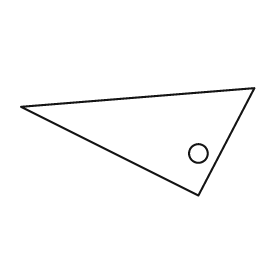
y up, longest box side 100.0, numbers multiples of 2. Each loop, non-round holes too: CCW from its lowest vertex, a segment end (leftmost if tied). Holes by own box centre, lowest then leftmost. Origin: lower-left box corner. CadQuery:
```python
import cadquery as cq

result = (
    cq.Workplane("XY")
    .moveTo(76.0, 0.0)
    .lineTo(100.0, 46.0)
    .lineTo(0.0, 38.0)
    .close()
    .moveTo(76.0, 18.0)
    .circle(4.0)
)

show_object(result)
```